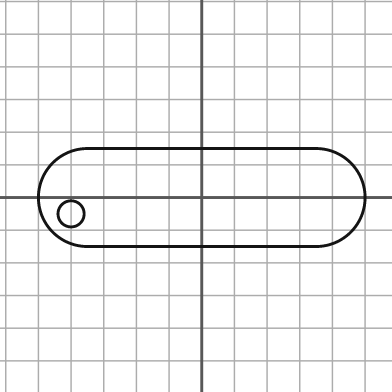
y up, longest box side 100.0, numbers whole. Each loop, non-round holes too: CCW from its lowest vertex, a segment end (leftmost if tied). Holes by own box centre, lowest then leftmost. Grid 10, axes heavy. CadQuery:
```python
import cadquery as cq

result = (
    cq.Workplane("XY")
    .moveTo(-35.0, -15.0)
    .lineTo(35.0, -15.0)
    .threePointArc((50.0, 0.0), (35.0, 15.0))
    .lineTo(-35.0, 15.0)
    .threePointArc((-50.0, 0.0), (-35.0, -15.0))
    .close()
    .moveTo(-40.0, -5.0)
    .circle(4.0)
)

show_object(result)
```